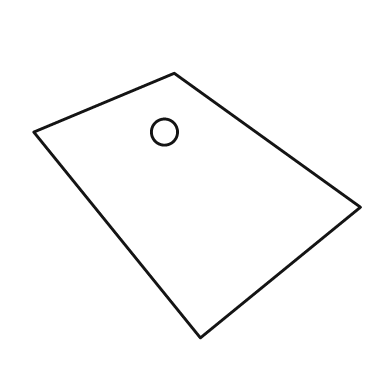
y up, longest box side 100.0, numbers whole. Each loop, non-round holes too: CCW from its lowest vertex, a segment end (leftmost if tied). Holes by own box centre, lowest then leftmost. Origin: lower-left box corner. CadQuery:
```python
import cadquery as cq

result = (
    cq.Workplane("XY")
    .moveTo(51.0, 0.0)
    .lineTo(100.0, 40.0)
    .lineTo(43.0, 81.0)
    .lineTo(0.0, 63.0)
    .close()
    .moveTo(40.0, 63.0)
    .circle(4.0)
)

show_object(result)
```